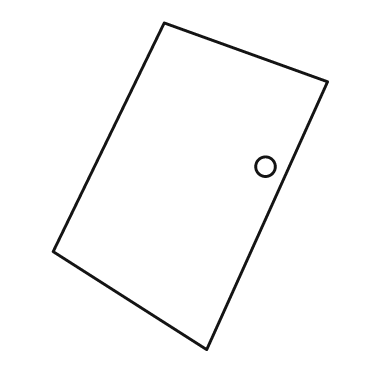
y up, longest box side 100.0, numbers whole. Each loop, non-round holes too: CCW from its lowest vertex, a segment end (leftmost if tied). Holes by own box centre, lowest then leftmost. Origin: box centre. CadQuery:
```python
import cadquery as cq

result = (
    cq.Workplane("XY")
    .moveTo(5.0, -50.0)
    .lineTo(42.0, 32.0)
    .lineTo(-8.0, 50.0)
    .lineTo(-42.0, -20.0)
    .close()
    .moveTo(23.0, 6.0)
    .circle(3.0)
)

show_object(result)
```